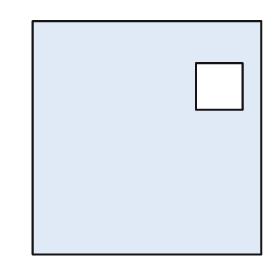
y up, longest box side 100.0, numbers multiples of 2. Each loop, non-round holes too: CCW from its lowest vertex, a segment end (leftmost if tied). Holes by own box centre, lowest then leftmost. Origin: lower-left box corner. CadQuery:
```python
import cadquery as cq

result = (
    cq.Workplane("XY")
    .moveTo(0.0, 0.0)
    .lineTo(98.0, 0.0)
    .lineTo(98.0, 100.0)
    .lineTo(0.0, 100.0)
    .close()
    .moveTo(70.0, 62.0)
    .lineTo(90.0, 62.0)
    .lineTo(90.0, 82.0)
    .lineTo(70.0, 82.0)
    .close()
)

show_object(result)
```